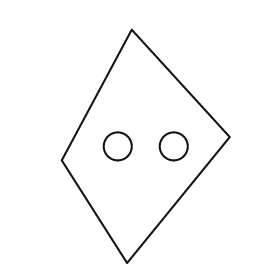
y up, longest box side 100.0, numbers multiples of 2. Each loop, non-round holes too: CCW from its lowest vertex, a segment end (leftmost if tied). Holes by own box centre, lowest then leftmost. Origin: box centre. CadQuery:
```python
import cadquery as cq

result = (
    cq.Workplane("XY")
    .moveTo(-8.0, -50.0)
    .lineTo(36.0, 4.0)
    .lineTo(-6.0, 50.0)
    .lineTo(-36.0, -6.0)
    .close()
    .moveTo(-12.0, 0.0)
    .circle(6.0)
    .moveTo(12.0, 0.0)
    .circle(6.0)
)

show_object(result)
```